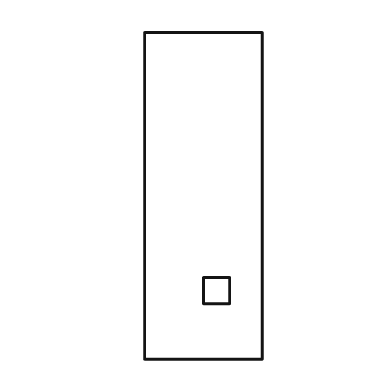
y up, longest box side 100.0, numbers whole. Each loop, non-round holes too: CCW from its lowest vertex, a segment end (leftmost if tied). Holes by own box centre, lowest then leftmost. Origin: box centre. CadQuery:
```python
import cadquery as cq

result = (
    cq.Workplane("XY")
    .moveTo(-18.0, -50.0)
    .lineTo(18.0, -50.0)
    .lineTo(18.0, 50.0)
    .lineTo(-18.0, 50.0)
    .close()
    .moveTo(0.0, -33.0)
    .lineTo(8.0, -33.0)
    .lineTo(8.0, -25.0)
    .lineTo(0.0, -25.0)
    .close()
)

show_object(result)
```